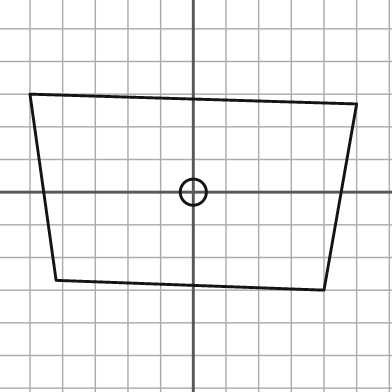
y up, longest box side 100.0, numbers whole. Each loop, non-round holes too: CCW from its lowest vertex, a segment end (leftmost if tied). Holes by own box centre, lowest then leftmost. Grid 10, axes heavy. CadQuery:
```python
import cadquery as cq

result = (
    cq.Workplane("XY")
    .moveTo(40.0, -30.0)
    .lineTo(50.0, 27.0)
    .lineTo(-50.0, 30.0)
    .lineTo(-42.0, -27.0)
    .close()
    .moveTo(0.0, 0.0)
    .circle(4.0)
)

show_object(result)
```